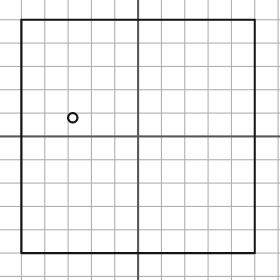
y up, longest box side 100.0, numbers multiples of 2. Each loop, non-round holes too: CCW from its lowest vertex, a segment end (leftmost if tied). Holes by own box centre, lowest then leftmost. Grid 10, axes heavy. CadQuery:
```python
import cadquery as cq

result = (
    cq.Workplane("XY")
    .moveTo(-50.0, -50.0)
    .lineTo(50.0, -50.0)
    .lineTo(50.0, 50.0)
    .lineTo(-50.0, 50.0)
    .close()
    .moveTo(-28.0, 8.0)
    .circle(2.0)
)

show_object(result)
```